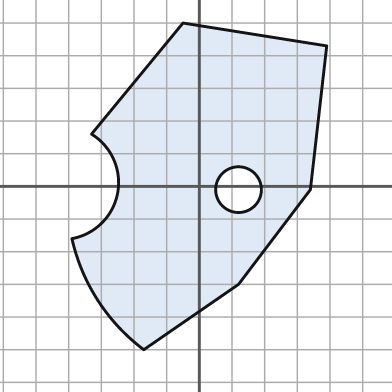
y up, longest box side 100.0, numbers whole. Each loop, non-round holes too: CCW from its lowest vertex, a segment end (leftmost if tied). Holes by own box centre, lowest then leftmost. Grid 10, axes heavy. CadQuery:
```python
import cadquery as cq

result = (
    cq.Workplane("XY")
    .moveTo(-17.0, -50.0)
    .lineTo(12.0, -30.0)
    .lineTo(34.0, -1.0)
    .lineTo(39.0, 43.0)
    .lineTo(-5.0, 50.0)
    .lineTo(-33.0, 16.0)
    .threePointArc((-25.0, -2.0), (-39.0, -16.0))
    .threePointArc((-31.0, -35.0), (-17.0, -50.0))
    .close()
    .moveTo(12.0, -1.0)
    .circle(7.0)
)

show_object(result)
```